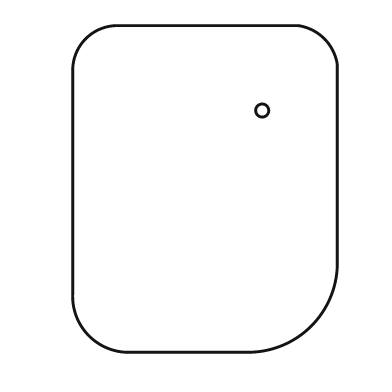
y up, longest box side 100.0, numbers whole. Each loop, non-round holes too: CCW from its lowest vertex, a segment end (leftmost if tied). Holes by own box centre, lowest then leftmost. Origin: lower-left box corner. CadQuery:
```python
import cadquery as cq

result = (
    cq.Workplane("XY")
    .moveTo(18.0, 0.0)
    .lineTo(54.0, 0.0)
    .threePointArc((73.0, 8.0), (81.0, 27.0))
    .lineTo(81.0, 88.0)
    .threePointArc((77.0, 96.0), (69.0, 100.0))
    .lineTo(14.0, 100.0)
    .threePointArc((4.0, 96.0), (0.0, 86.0))
    .lineTo(0.0, 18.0)
    .threePointArc((5.0, 5.0), (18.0, 0.0))
    .close()
    .moveTo(58.0, 74.0)
    .circle(2.0)
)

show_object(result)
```